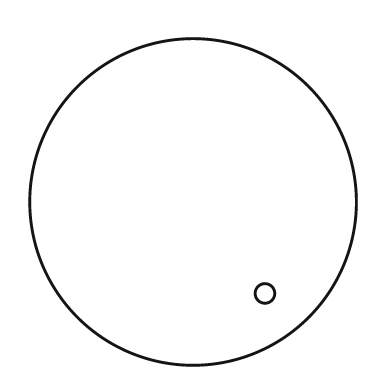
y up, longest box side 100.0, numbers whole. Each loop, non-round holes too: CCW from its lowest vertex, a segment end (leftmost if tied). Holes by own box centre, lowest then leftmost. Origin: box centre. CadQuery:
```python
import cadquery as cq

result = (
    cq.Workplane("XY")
    .moveTo(0.0, 0.0)
    .circle(50.0)
    .moveTo(22.0, -28.0)
    .circle(3.0)
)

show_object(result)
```